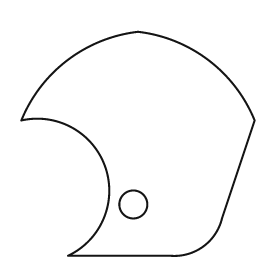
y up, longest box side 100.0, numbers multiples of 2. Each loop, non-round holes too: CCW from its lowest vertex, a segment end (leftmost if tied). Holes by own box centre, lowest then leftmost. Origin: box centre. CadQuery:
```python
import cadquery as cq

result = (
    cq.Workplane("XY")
    .moveTo(-30.0, -48.0)
    .lineTo(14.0, -48.0)
    .threePointArc((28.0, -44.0), (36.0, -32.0))
    .lineTo(50.0, 10.0)
    .threePointArc((30.0, 36.0), (0.0, 48.0))
    .threePointArc((-30.0, 36.0), (-50.0, 10.0))
    .threePointArc((-14.0, -10.0), (-30.0, -48.0))
    .close()
    .moveTo(-2.0, -26.0)
    .circle(6.0)
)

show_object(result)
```